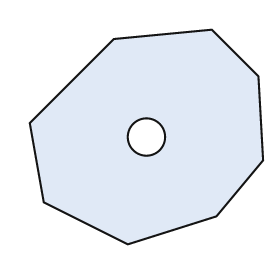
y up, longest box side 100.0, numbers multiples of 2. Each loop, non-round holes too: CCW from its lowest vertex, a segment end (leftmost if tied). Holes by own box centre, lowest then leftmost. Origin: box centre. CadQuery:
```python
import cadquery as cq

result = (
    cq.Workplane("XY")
    .moveTo(-8.0, -46.0)
    .lineTo(30.0, -34.0)
    .lineTo(50.0, -10.0)
    .lineTo(48.0, 26.0)
    .lineTo(28.0, 46.0)
    .lineTo(-14.0, 42.0)
    .lineTo(-50.0, 6.0)
    .lineTo(-44.0, -28.0)
    .close()
    .moveTo(0.0, 0.0)
    .circle(8.0)
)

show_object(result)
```